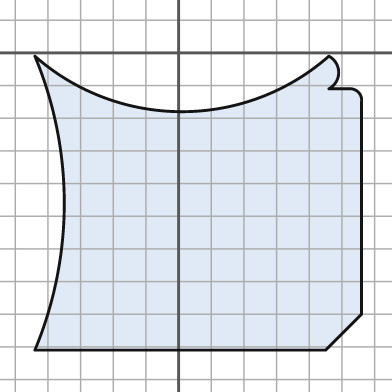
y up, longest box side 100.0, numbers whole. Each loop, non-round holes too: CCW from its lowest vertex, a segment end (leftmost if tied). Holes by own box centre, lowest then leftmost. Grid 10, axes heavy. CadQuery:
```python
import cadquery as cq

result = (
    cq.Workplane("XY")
    .moveTo(-44.0, -91.0)
    .lineTo(45.0, -91.0)
    .lineTo(56.0, -80.0)
    .lineTo(56.0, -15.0)
    .threePointArc((55.0, -12.0), (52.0, -11.0))
    .lineTo(46.0, -11.0)
    .threePointArc((49.0, -6.0), (46.0, -1.0))
    .threePointArc((1.0, -18.0), (-44.0, -1.0))
    .threePointArc((-35.0, -46.0), (-44.0, -91.0))
    .close()
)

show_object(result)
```